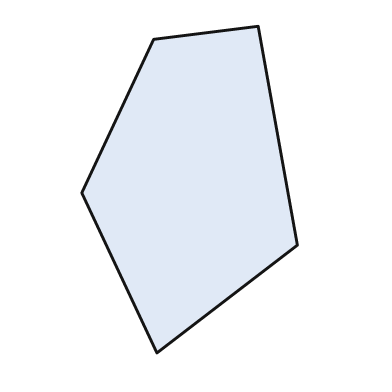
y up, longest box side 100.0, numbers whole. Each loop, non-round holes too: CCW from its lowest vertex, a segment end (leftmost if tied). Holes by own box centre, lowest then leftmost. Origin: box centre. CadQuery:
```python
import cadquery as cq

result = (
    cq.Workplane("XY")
    .moveTo(-10.0, -50.0)
    .lineTo(33.0, -17.0)
    .lineTo(21.0, 50.0)
    .lineTo(-11.0, 46.0)
    .lineTo(-33.0, -1.0)
    .close()
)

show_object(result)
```